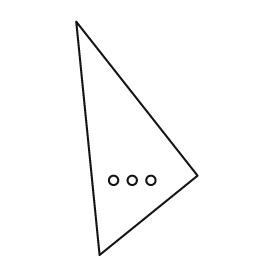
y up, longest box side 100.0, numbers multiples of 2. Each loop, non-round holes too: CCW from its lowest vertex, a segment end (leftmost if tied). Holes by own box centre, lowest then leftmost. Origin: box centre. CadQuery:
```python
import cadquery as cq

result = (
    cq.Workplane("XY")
    .moveTo(-16.0, -50.0)
    .lineTo(26.0, -16.0)
    .lineTo(-26.0, 50.0)
    .close()
    .moveTo(-10.0, -18.0)
    .circle(2.0)
    .moveTo(-2.0, -18.0)
    .circle(2.0)
    .moveTo(6.0, -18.0)
    .circle(2.0)
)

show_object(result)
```